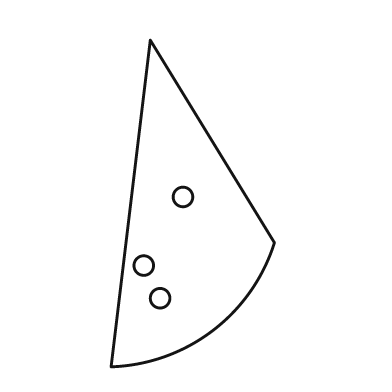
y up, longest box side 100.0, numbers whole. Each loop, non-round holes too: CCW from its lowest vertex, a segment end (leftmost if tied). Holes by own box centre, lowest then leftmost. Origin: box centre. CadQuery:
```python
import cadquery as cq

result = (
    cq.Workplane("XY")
    .moveTo(-25.0, -50.0)
    .threePointArc((6.0, -39.0), (25.0, -12.0))
    .lineTo(-13.0, 50.0)
    .close()
    .moveTo(-10.0, -29.0)
    .circle(3.0)
    .moveTo(-15.0, -19.0)
    .circle(3.0)
    .moveTo(-3.0, 2.0)
    .circle(3.0)
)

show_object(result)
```